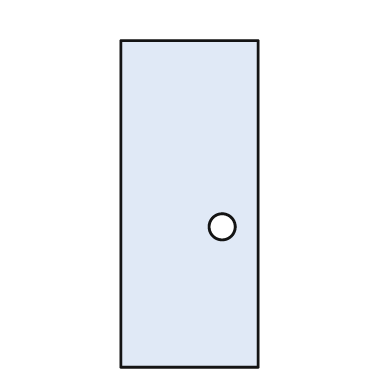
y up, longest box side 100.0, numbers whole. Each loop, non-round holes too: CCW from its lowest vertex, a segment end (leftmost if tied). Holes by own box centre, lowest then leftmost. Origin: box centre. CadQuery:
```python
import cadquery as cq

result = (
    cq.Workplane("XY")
    .moveTo(-21.0, -50.0)
    .lineTo(21.0, -50.0)
    .lineTo(21.0, 50.0)
    .lineTo(-21.0, 50.0)
    .close()
    .moveTo(10.0, -7.0)
    .circle(4.0)
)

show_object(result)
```